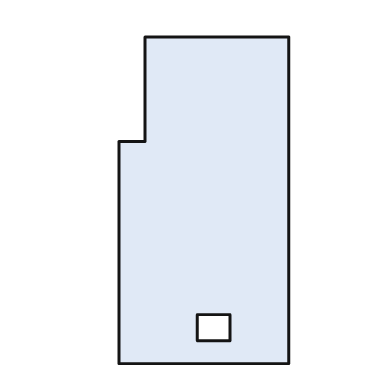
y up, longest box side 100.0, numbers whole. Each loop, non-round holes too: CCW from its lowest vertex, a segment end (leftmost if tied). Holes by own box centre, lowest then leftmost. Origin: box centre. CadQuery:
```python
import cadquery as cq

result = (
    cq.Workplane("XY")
    .moveTo(-26.0, -50.0)
    .lineTo(26.0, -50.0)
    .lineTo(26.0, 50.0)
    .lineTo(-18.0, 50.0)
    .lineTo(-18.0, 18.0)
    .lineTo(-26.0, 18.0)
    .close()
    .moveTo(-2.0, -43.0)
    .lineTo(8.0, -43.0)
    .lineTo(8.0, -35.0)
    .lineTo(-2.0, -35.0)
    .close()
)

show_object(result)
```